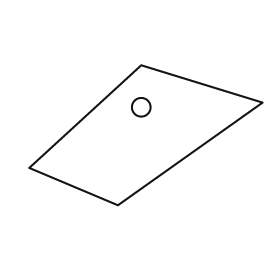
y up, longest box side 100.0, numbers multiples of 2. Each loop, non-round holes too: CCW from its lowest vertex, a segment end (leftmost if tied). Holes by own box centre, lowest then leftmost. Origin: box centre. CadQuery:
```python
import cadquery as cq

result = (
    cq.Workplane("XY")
    .moveTo(-12.0, -30.0)
    .lineTo(50.0, 14.0)
    .lineTo(-2.0, 30.0)
    .lineTo(-50.0, -14.0)
    .close()
    .moveTo(-2.0, 12.0)
    .circle(4.0)
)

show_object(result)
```